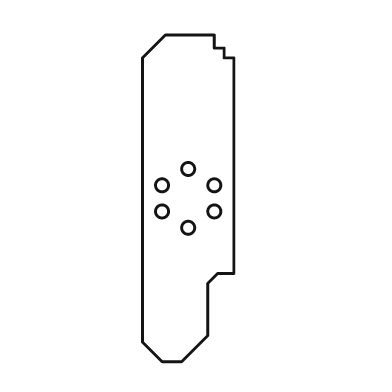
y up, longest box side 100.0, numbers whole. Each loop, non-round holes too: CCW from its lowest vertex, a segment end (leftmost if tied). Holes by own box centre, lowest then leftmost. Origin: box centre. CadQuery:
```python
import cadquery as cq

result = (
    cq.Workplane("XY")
    .moveTo(-8.0, -50.0)
    .lineTo(-2.0, -50.0)
    .lineTo(6.0, -42.0)
    .lineTo(6.0, -26.0)
    .lineTo(9.0, -23.0)
    .lineTo(14.0, -23.0)
    .lineTo(14.0, 43.0)
    .lineTo(11.0, 43.0)
    .lineTo(11.0, 46.0)
    .lineTo(8.0, 46.0)
    .lineTo(8.0, 50.0)
    .lineTo(-7.0, 50.0)
    .lineTo(-14.0, 43.0)
    .lineTo(-14.0, -44.0)
    .close()
    .moveTo(0.0, -9.0)
    .circle(2.0)
    .moveTo(-8.0, -4.0)
    .circle(2.0)
    .moveTo(8.0, -4.0)
    .circle(2.0)
    .moveTo(-8.0, 4.0)
    .circle(2.0)
    .moveTo(8.0, 4.0)
    .circle(2.0)
    .moveTo(0.0, 9.0)
    .circle(2.0)
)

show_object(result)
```